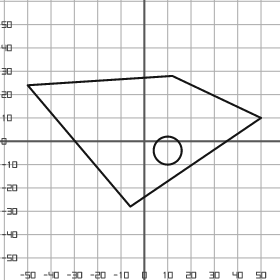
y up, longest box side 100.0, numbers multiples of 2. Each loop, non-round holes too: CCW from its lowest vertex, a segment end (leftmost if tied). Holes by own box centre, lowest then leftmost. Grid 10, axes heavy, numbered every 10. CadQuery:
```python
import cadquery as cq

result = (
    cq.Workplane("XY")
    .moveTo(-6.0, -28.0)
    .lineTo(50.0, 10.0)
    .lineTo(12.0, 28.0)
    .lineTo(-50.0, 24.0)
    .close()
    .moveTo(10.0, -4.0)
    .circle(6.0)
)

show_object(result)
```